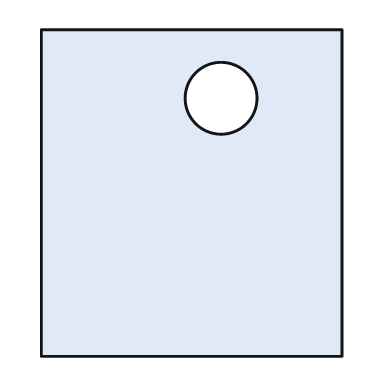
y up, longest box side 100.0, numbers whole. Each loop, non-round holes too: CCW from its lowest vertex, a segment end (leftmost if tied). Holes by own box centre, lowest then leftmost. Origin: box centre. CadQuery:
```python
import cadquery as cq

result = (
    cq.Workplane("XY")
    .moveTo(-46.0, -50.0)
    .lineTo(46.0, -50.0)
    .lineTo(46.0, 50.0)
    .lineTo(-46.0, 50.0)
    .close()
    .moveTo(9.0, 29.0)
    .circle(11.0)
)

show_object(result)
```